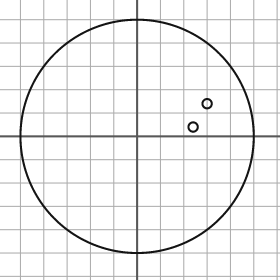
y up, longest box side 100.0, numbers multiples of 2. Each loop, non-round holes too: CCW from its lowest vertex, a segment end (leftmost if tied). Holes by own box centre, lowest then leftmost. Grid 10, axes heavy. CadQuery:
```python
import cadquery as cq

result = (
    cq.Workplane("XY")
    .moveTo(0.0, 0.0)
    .circle(50.0)
    .moveTo(24.0, 4.0)
    .circle(2.0)
    .moveTo(30.0, 14.0)
    .circle(2.0)
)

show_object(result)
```